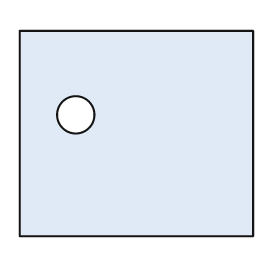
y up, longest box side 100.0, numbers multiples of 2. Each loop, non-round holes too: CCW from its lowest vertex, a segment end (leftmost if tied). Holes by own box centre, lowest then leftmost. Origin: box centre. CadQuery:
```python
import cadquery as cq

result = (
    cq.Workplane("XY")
    .moveTo(-50.0, -44.0)
    .lineTo(50.0, -44.0)
    .lineTo(50.0, 44.0)
    .lineTo(-50.0, 44.0)
    .close()
    .moveTo(-26.0, 8.0)
    .circle(8.0)
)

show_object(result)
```